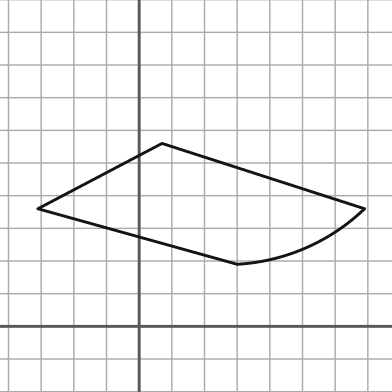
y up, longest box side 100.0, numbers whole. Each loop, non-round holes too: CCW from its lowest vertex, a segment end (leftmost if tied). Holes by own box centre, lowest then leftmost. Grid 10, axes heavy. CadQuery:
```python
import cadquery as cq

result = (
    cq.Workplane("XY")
    .moveTo(30.0, 19.0)
    .threePointArc((51.0, 24.0), (69.0, 36.0))
    .lineTo(7.0, 56.0)
    .lineTo(-31.0, 36.0)
    .close()
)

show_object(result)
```